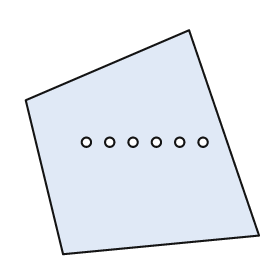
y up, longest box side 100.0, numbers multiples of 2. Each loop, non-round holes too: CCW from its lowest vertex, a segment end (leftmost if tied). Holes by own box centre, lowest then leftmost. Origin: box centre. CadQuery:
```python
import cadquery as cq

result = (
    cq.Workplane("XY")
    .moveTo(-34.0, -48.0)
    .lineTo(50.0, -40.0)
    .lineTo(20.0, 48.0)
    .lineTo(-50.0, 18.0)
    .close()
    .moveTo(-24.0, 0.0)
    .circle(2.0)
    .moveTo(-14.0, 0.0)
    .circle(2.0)
    .moveTo(-4.0, 0.0)
    .circle(2.0)
    .moveTo(6.0, 0.0)
    .circle(2.0)
    .moveTo(16.0, 0.0)
    .circle(2.0)
    .moveTo(26.0, 0.0)
    .circle(2.0)
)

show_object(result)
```